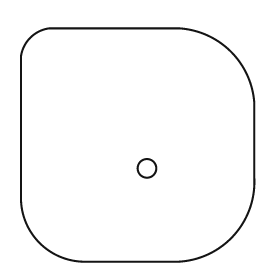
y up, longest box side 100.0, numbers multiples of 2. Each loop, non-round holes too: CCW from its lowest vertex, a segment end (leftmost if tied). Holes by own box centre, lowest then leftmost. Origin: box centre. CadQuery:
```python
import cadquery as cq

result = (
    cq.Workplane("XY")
    .moveTo(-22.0, -50.0)
    .lineTo(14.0, -50.0)
    .threePointArc((40.0, -40.0), (50.0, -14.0))
    .lineTo(50.0, 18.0)
    .threePointArc((40.0, 40.0), (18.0, 50.0))
    .lineTo(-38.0, 50.0)
    .threePointArc((-46.0, 46.0), (-50.0, 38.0))
    .lineTo(-50.0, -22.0)
    .threePointArc((-42.0, -42.0), (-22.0, -50.0))
    .close()
    .moveTo(4.0, -10.0)
    .circle(4.0)
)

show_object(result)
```